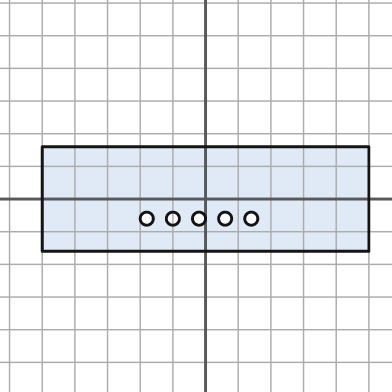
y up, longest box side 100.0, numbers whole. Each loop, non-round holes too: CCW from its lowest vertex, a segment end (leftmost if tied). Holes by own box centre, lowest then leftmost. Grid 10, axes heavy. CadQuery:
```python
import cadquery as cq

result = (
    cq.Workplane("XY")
    .moveTo(-50.0, -16.0)
    .lineTo(50.0, -16.0)
    .lineTo(50.0, 16.0)
    .lineTo(-50.0, 16.0)
    .close()
    .moveTo(-18.0, -6.0)
    .circle(2.0)
    .moveTo(-10.0, -6.0)
    .circle(2.0)
    .moveTo(-2.0, -6.0)
    .circle(2.0)
    .moveTo(6.0, -6.0)
    .circle(2.0)
    .moveTo(14.0, -6.0)
    .circle(2.0)
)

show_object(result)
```